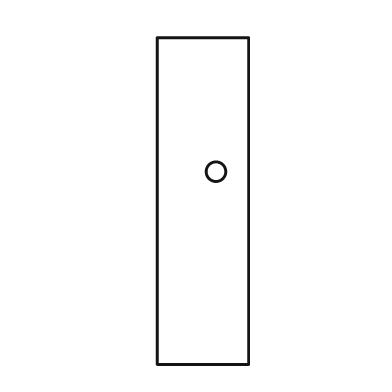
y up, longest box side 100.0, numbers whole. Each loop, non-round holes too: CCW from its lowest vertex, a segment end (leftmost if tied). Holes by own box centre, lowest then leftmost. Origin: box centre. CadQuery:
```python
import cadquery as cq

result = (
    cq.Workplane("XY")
    .moveTo(-14.0, -50.0)
    .lineTo(14.0, -50.0)
    .lineTo(14.0, 50.0)
    .lineTo(-14.0, 50.0)
    .close()
    .moveTo(4.0, 9.0)
    .circle(3.0)
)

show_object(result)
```